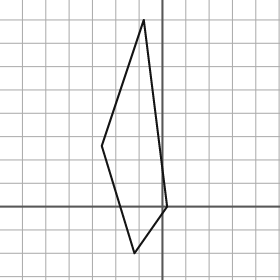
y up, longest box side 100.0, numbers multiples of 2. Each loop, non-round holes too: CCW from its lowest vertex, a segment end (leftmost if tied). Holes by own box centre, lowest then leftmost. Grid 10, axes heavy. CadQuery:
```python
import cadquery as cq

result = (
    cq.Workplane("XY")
    .moveTo(-12.0, -20.0)
    .lineTo(2.0, 0.0)
    .lineTo(-8.0, 80.0)
    .lineTo(-26.0, 26.0)
    .close()
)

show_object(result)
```